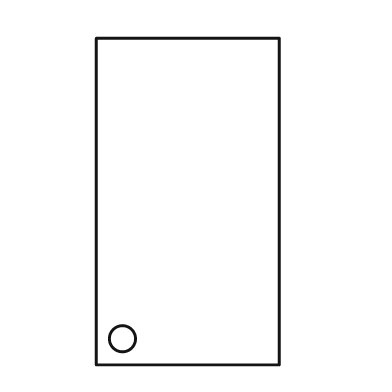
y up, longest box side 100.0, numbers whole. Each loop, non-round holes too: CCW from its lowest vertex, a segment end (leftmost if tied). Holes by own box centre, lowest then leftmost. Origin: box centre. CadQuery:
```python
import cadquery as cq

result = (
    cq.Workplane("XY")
    .moveTo(-28.0, -50.0)
    .lineTo(28.0, -50.0)
    .lineTo(28.0, 50.0)
    .lineTo(-28.0, 50.0)
    .close()
    .moveTo(-20.0, -42.0)
    .circle(4.0)
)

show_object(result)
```